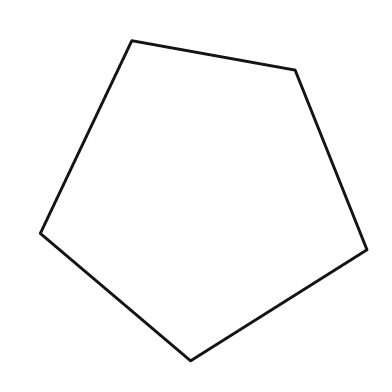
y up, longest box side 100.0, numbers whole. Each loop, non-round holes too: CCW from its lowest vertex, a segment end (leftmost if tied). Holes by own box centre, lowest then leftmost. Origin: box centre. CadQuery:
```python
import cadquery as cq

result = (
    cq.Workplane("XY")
    .moveTo(-4.0, -49.0)
    .lineTo(50.0, -15.0)
    .lineTo(28.0, 40.0)
    .lineTo(-22.0, 49.0)
    .lineTo(-50.0, -10.0)
    .close()
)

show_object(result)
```